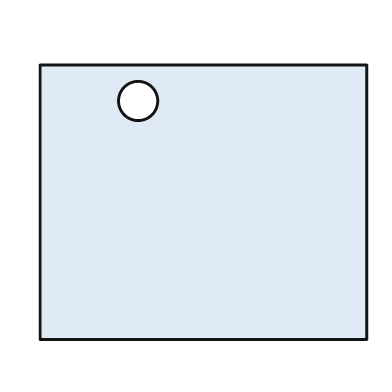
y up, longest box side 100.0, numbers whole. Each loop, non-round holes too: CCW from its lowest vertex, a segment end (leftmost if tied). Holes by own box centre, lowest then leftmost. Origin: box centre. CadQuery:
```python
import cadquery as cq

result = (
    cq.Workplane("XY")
    .moveTo(-50.0, -42.0)
    .lineTo(50.0, -42.0)
    .lineTo(50.0, 42.0)
    .lineTo(-50.0, 42.0)
    .close()
    .moveTo(-20.0, 31.0)
    .circle(6.0)
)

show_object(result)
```